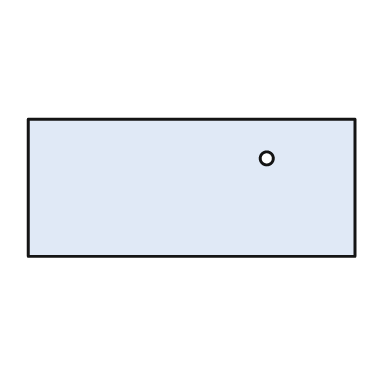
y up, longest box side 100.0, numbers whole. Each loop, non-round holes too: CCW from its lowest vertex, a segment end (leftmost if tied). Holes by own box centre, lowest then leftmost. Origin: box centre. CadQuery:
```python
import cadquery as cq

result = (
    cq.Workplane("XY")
    .moveTo(-50.0, -21.0)
    .lineTo(50.0, -21.0)
    .lineTo(50.0, 21.0)
    .lineTo(-50.0, 21.0)
    .close()
    .moveTo(23.0, 9.0)
    .circle(2.0)
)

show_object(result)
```